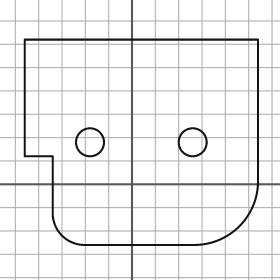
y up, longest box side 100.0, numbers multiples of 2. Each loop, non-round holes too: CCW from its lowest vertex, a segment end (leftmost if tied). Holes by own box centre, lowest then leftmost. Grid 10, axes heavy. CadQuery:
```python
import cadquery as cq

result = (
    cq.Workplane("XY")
    .moveTo(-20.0, -26.0)
    .lineTo(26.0, -26.0)
    .threePointArc((46.0, -18.0), (54.0, 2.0))
    .lineTo(54.0, 62.0)
    .lineTo(-46.0, 62.0)
    .lineTo(-46.0, 12.0)
    .lineTo(-34.0, 12.0)
    .lineTo(-34.0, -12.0)
    .threePointArc((-30.0, -22.0), (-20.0, -26.0))
    .close()
    .moveTo(-18.0, 18.0)
    .circle(6.0)
    .moveTo(26.0, 18.0)
    .circle(6.0)
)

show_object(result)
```